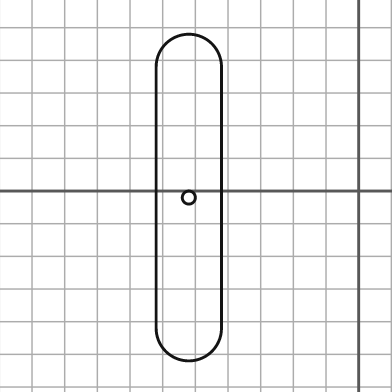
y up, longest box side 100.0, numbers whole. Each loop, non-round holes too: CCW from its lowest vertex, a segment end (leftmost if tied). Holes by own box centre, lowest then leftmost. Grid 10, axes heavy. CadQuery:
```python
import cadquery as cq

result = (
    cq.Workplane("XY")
    .moveTo(-62.0, -42.0)
    .threePointArc((-52.0, -52.0), (-42.0, -42.0))
    .lineTo(-42.0, 38.0)
    .threePointArc((-52.0, 48.0), (-62.0, 38.0))
    .close()
    .moveTo(-52.0, -2.0)
    .circle(2.0)
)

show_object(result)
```